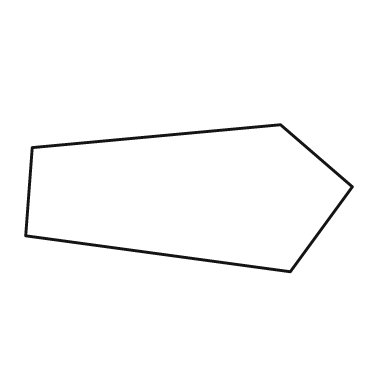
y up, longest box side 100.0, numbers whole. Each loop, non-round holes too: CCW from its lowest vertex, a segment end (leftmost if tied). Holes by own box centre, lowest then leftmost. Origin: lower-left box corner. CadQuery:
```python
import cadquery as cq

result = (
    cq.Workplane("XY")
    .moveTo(81.0, 0.0)
    .lineTo(100.0, 26.0)
    .lineTo(78.0, 45.0)
    .lineTo(2.0, 38.0)
    .lineTo(0.0, 11.0)
    .close()
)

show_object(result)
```